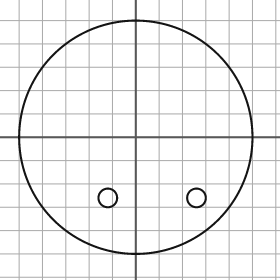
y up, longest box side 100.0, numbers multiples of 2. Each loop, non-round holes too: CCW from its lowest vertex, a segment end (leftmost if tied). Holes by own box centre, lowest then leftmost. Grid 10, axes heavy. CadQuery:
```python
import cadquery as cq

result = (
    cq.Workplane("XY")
    .moveTo(0.0, 0.0)
    .circle(50.0)
    .moveTo(-12.0, -26.0)
    .circle(4.0)
    .moveTo(26.0, -26.0)
    .circle(4.0)
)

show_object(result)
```